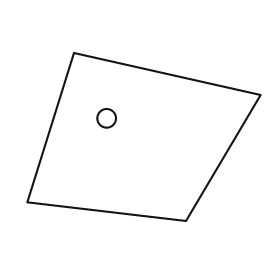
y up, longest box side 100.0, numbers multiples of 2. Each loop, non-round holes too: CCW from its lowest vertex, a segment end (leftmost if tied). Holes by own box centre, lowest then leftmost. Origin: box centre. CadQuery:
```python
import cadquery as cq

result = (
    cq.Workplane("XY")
    .moveTo(18.0, -36.0)
    .lineTo(50.0, 18.0)
    .lineTo(-30.0, 36.0)
    .lineTo(-50.0, -28.0)
    .close()
    .moveTo(-16.0, 8.0)
    .circle(4.0)
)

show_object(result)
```